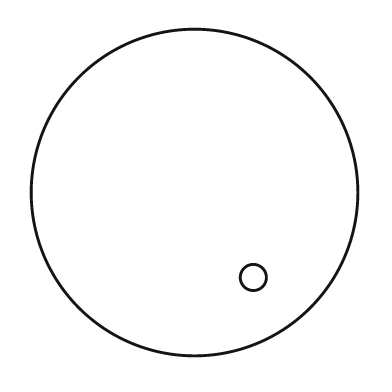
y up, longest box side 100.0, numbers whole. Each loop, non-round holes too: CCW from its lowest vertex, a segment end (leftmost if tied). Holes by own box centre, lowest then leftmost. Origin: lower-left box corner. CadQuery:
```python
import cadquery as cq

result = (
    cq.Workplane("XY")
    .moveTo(50.0, 50.0)
    .circle(50.0)
    .moveTo(68.0, 24.0)
    .circle(4.0)
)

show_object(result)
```